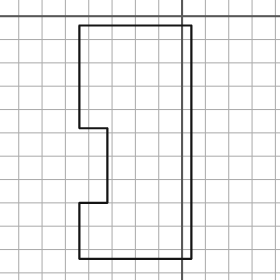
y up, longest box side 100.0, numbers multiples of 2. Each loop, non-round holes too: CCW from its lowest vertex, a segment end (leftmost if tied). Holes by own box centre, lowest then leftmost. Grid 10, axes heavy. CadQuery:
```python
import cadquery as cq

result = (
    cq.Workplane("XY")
    .moveTo(-44.0, -104.0)
    .lineTo(4.0, -104.0)
    .lineTo(4.0, -4.0)
    .lineTo(-44.0, -4.0)
    .lineTo(-44.0, -48.0)
    .lineTo(-32.0, -48.0)
    .lineTo(-32.0, -80.0)
    .lineTo(-44.0, -80.0)
    .close()
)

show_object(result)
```